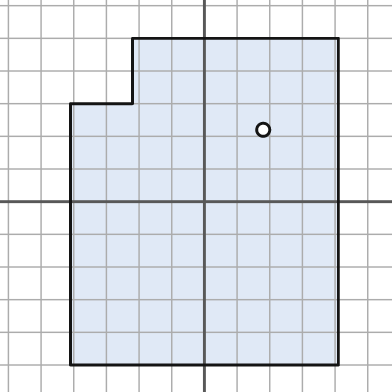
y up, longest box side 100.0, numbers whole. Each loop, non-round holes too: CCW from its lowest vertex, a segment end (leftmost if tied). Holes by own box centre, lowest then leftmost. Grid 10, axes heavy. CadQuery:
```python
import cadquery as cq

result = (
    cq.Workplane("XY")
    .moveTo(-41.0, -50.0)
    .lineTo(41.0, -50.0)
    .lineTo(41.0, 50.0)
    .lineTo(-22.0, 50.0)
    .lineTo(-22.0, 30.0)
    .lineTo(-41.0, 30.0)
    .close()
    .moveTo(18.0, 22.0)
    .circle(2.0)
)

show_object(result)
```